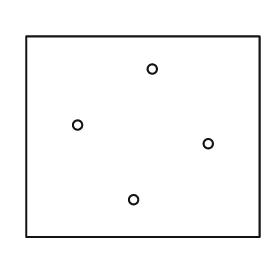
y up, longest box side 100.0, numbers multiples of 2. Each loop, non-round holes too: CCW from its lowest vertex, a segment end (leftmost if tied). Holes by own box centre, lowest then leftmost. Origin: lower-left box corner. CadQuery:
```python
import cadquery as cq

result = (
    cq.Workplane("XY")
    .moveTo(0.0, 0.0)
    .lineTo(100.0, 0.0)
    .lineTo(100.0, 86.0)
    .lineTo(0.0, 86.0)
    .close()
    .moveTo(46.0, 16.0)
    .circle(2.0)
    .moveTo(78.0, 40.0)
    .circle(2.0)
    .moveTo(22.0, 48.0)
    .circle(2.0)
    .moveTo(54.0, 72.0)
    .circle(2.0)
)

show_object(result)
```